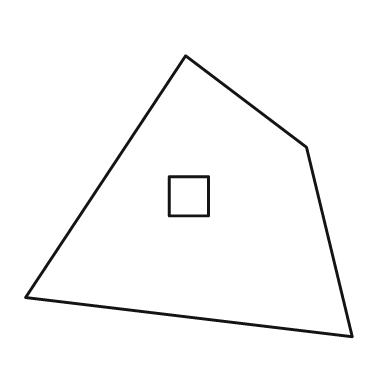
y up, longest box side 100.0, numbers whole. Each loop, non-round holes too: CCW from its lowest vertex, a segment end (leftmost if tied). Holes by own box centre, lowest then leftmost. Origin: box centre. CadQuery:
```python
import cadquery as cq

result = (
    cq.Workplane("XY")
    .moveTo(50.0, -43.0)
    .lineTo(36.0, 15.0)
    .lineTo(-1.0, 43.0)
    .lineTo(-50.0, -31.0)
    .close()
    .moveTo(-6.0, -6.0)
    .lineTo(6.0, -6.0)
    .lineTo(6.0, 6.0)
    .lineTo(-6.0, 6.0)
    .close()
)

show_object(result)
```